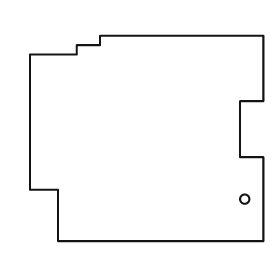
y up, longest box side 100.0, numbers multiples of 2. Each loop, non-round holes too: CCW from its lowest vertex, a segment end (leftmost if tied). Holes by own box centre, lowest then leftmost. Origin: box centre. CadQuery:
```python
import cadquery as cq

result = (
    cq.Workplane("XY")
    .moveTo(-38.0, -44.0)
    .lineTo(50.0, -44.0)
    .lineTo(50.0, -8.0)
    .lineTo(40.0, -8.0)
    .lineTo(40.0, 16.0)
    .lineTo(50.0, 16.0)
    .lineTo(50.0, 44.0)
    .lineTo(-20.0, 44.0)
    .lineTo(-20.0, 40.0)
    .lineTo(-30.0, 40.0)
    .lineTo(-30.0, 36.0)
    .lineTo(-50.0, 36.0)
    .lineTo(-50.0, -22.0)
    .lineTo(-38.0, -22.0)
    .close()
    .moveTo(42.0, -26.0)
    .circle(2.0)
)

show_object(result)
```